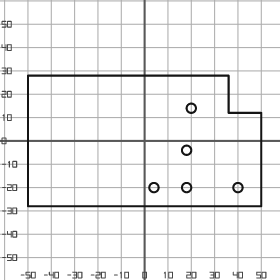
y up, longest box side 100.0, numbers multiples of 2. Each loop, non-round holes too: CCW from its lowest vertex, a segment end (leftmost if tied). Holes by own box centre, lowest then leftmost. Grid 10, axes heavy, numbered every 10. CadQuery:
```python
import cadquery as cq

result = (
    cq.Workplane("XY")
    .moveTo(-50.0, -28.0)
    .lineTo(50.0, -28.0)
    .lineTo(50.0, 12.0)
    .lineTo(36.0, 12.0)
    .lineTo(36.0, 28.0)
    .lineTo(-50.0, 28.0)
    .close()
    .moveTo(4.0, -20.0)
    .circle(2.0)
    .moveTo(18.0, -20.0)
    .circle(2.0)
    .moveTo(40.0, -20.0)
    .circle(2.0)
    .moveTo(18.0, -4.0)
    .circle(2.0)
    .moveTo(20.0, 14.0)
    .circle(2.0)
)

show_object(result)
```